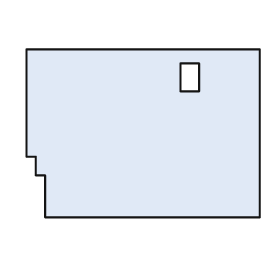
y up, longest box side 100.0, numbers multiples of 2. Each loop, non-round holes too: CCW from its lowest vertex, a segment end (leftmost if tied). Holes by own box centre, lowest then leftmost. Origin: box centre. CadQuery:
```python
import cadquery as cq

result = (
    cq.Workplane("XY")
    .moveTo(-42.0, -36.0)
    .lineTo(50.0, -36.0)
    .lineTo(50.0, 36.0)
    .lineTo(-50.0, 36.0)
    .lineTo(-50.0, -10.0)
    .lineTo(-46.0, -10.0)
    .lineTo(-46.0, -18.0)
    .lineTo(-42.0, -18.0)
    .close()
    .moveTo(16.0, 18.0)
    .lineTo(24.0, 18.0)
    .lineTo(24.0, 30.0)
    .lineTo(16.0, 30.0)
    .close()
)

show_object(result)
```